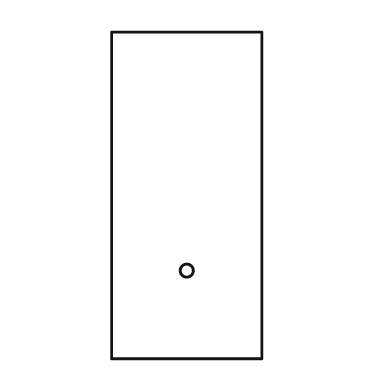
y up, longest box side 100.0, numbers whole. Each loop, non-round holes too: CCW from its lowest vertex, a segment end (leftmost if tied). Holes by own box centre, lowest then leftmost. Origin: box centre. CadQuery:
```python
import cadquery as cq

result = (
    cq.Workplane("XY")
    .moveTo(-23.0, -50.0)
    .lineTo(23.0, -50.0)
    .lineTo(23.0, 50.0)
    .lineTo(-23.0, 50.0)
    .close()
    .moveTo(0.0, -23.0)
    .circle(2.0)
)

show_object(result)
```